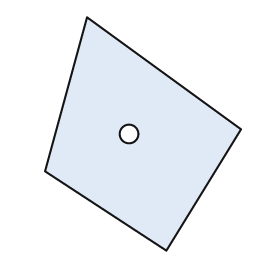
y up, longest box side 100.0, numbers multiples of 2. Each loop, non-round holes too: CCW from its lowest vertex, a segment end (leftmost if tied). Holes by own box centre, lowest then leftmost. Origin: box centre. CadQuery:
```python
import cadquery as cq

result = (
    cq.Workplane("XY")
    .moveTo(10.0, -50.0)
    .lineTo(42.0, 2.0)
    .lineTo(-24.0, 50.0)
    .lineTo(-42.0, -16.0)
    .close()
    .moveTo(-6.0, 0.0)
    .circle(4.0)
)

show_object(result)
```